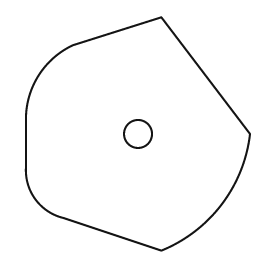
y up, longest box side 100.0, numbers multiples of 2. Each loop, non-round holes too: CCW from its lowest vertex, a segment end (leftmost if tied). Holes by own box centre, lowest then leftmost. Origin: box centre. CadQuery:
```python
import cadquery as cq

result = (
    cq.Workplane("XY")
    .moveTo(10.0, -50.0)
    .threePointArc((36.0, -30.0), (48.0, 0.0))
    .lineTo(10.0, 50.0)
    .lineTo(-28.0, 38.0)
    .threePointArc((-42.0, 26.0), (-48.0, 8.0))
    .lineTo(-48.0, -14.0)
    .threePointArc((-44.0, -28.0), (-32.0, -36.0))
    .close()
    .moveTo(0.0, 0.0)
    .circle(6.0)
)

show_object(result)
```